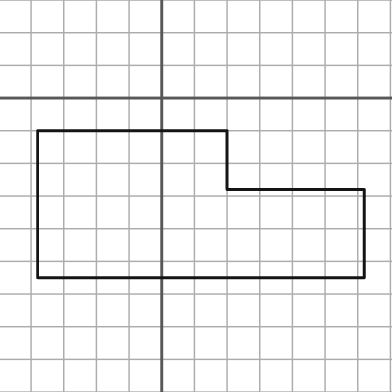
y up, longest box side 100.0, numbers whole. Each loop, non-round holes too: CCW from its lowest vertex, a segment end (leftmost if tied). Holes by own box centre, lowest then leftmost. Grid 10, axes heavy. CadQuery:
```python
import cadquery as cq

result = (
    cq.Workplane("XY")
    .moveTo(-38.0, -55.0)
    .lineTo(62.0, -55.0)
    .lineTo(62.0, -28.0)
    .lineTo(20.0, -28.0)
    .lineTo(20.0, -10.0)
    .lineTo(-38.0, -10.0)
    .close()
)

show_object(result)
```